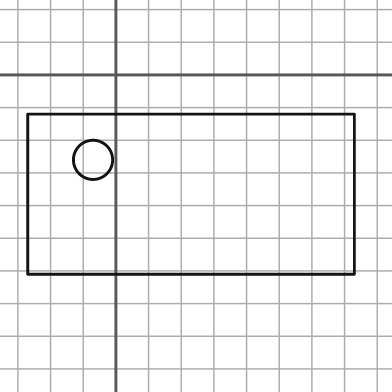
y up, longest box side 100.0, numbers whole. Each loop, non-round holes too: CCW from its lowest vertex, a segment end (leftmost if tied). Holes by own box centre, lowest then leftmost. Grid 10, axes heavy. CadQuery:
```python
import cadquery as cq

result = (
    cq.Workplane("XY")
    .moveTo(-27.0, -61.0)
    .lineTo(73.0, -61.0)
    .lineTo(73.0, -12.0)
    .lineTo(-27.0, -12.0)
    .close()
    .moveTo(-7.0, -26.0)
    .circle(6.0)
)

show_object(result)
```